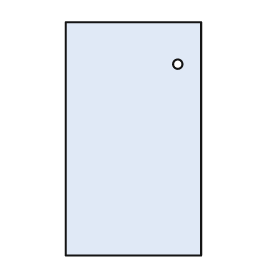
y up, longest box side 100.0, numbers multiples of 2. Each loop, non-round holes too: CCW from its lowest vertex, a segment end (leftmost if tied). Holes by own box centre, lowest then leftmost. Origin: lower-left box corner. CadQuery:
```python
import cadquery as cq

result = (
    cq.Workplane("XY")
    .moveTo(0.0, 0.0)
    .lineTo(58.0, 0.0)
    .lineTo(58.0, 100.0)
    .lineTo(0.0, 100.0)
    .close()
    .moveTo(48.0, 82.0)
    .circle(2.0)
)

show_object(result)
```